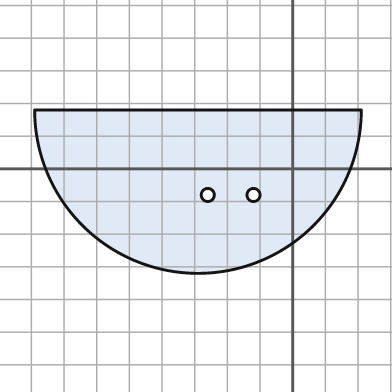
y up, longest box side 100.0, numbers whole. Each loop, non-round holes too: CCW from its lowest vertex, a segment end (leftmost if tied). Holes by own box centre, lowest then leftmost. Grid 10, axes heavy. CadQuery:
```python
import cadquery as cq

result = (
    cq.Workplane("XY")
    .moveTo(-79.0, 18.0)
    .threePointArc((-29.0, -32.0), (21.0, 18.0))
    .close()
    .moveTo(-26.0, -8.0)
    .circle(2.0)
    .moveTo(-12.0, -8.0)
    .circle(2.0)
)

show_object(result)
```